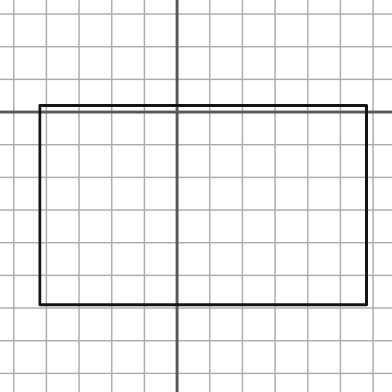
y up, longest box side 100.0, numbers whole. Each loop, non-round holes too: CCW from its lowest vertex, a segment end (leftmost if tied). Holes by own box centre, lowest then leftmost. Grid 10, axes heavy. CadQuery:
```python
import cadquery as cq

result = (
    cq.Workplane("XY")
    .moveTo(-42.0, -59.0)
    .lineTo(58.0, -59.0)
    .lineTo(58.0, 2.0)
    .lineTo(-42.0, 2.0)
    .close()
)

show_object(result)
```